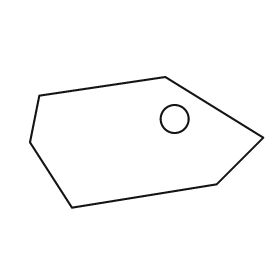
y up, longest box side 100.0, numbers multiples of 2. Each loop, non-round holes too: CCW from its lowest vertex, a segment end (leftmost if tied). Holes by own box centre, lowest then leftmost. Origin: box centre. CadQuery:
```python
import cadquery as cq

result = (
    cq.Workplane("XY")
    .moveTo(-32.0, -28.0)
    .lineTo(30.0, -18.0)
    .lineTo(50.0, 2.0)
    .lineTo(8.0, 28.0)
    .lineTo(-46.0, 20.0)
    .lineTo(-50.0, 0.0)
    .close()
    .moveTo(12.0, 10.0)
    .circle(6.0)
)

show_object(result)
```